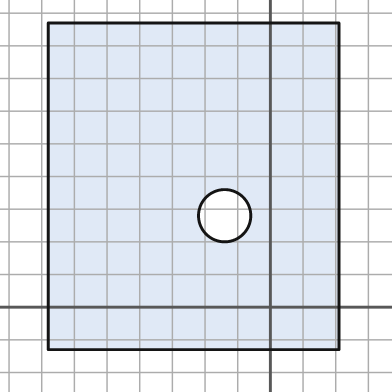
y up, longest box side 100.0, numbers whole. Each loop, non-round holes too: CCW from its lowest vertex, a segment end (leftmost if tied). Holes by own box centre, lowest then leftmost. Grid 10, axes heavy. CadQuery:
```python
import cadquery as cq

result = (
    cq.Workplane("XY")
    .moveTo(-68.0, -13.0)
    .lineTo(21.0, -13.0)
    .lineTo(21.0, 87.0)
    .lineTo(-68.0, 87.0)
    .close()
    .moveTo(-14.0, 28.0)
    .circle(8.0)
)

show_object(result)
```